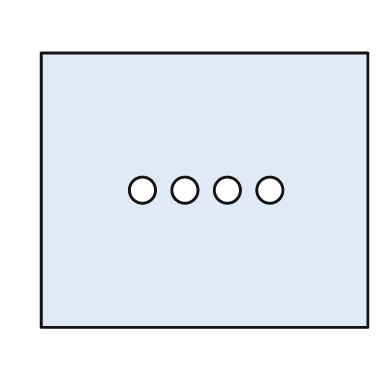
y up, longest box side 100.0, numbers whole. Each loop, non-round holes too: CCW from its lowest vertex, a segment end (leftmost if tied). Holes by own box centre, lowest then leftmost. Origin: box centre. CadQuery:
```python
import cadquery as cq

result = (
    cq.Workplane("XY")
    .moveTo(-50.0, -42.0)
    .lineTo(50.0, -42.0)
    .lineTo(50.0, 42.0)
    .lineTo(-50.0, 42.0)
    .close()
    .moveTo(-19.0, 0.0)
    .circle(4.0)
    .moveTo(-6.0, 0.0)
    .circle(4.0)
    .moveTo(7.0, 0.0)
    .circle(4.0)
    .moveTo(20.0, 0.0)
    .circle(4.0)
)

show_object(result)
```